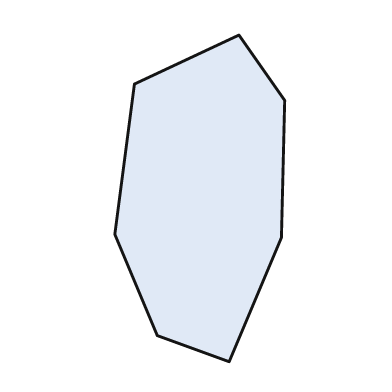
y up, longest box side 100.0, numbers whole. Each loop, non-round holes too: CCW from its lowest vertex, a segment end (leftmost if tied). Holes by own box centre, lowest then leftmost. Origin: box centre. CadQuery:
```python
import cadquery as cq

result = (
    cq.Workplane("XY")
    .moveTo(9.0, -50.0)
    .lineTo(25.0, -12.0)
    .lineTo(26.0, 30.0)
    .lineTo(12.0, 50.0)
    .lineTo(-20.0, 35.0)
    .lineTo(-26.0, -11.0)
    .lineTo(-13.0, -42.0)
    .close()
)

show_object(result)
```